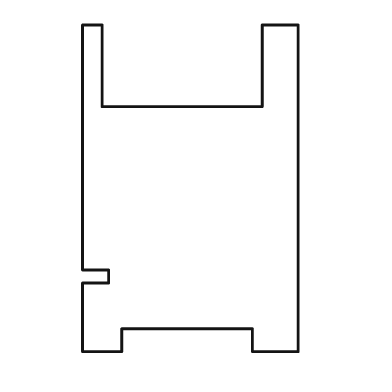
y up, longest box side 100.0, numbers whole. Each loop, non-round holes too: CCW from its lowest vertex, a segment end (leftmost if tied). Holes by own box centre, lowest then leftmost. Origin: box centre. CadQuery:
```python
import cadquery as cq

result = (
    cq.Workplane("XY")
    .moveTo(-33.0, -50.0)
    .lineTo(-21.0, -50.0)
    .lineTo(-21.0, -43.0)
    .lineTo(19.0, -43.0)
    .lineTo(19.0, -50.0)
    .lineTo(33.0, -50.0)
    .lineTo(33.0, 50.0)
    .lineTo(22.0, 50.0)
    .lineTo(22.0, 25.0)
    .lineTo(-27.0, 25.0)
    .lineTo(-27.0, 50.0)
    .lineTo(-33.0, 50.0)
    .lineTo(-33.0, -25.0)
    .lineTo(-25.0, -25.0)
    .lineTo(-25.0, -29.0)
    .lineTo(-33.0, -29.0)
    .close()
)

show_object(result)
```